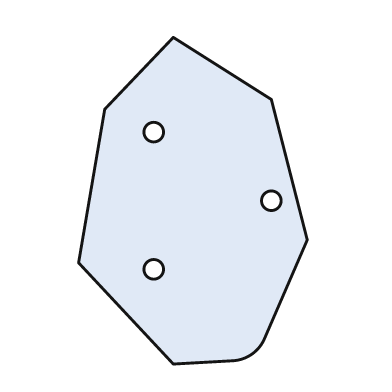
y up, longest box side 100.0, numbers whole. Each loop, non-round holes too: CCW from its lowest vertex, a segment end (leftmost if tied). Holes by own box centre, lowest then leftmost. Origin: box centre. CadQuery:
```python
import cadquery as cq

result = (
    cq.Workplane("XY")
    .moveTo(-6.0, -50.0)
    .lineTo(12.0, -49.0)
    .threePointArc((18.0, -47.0), (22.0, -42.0))
    .lineTo(35.0, -12.0)
    .lineTo(24.0, 31.0)
    .lineTo(-6.0, 50.0)
    .lineTo(-27.0, 28.0)
    .lineTo(-35.0, -19.0)
    .close()
    .moveTo(-12.0, -21.0)
    .circle(3.0)
    .moveTo(24.0, 0.0)
    .circle(3.0)
    .moveTo(-12.0, 21.0)
    .circle(3.0)
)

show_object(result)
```